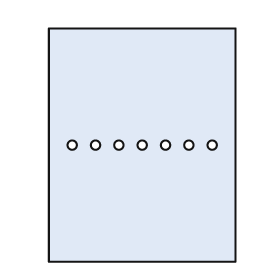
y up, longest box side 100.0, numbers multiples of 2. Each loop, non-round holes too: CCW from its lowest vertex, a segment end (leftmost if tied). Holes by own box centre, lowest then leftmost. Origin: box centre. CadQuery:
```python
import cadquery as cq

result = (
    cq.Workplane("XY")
    .moveTo(-40.0, -50.0)
    .lineTo(40.0, -50.0)
    .lineTo(40.0, 50.0)
    .lineTo(-40.0, 50.0)
    .close()
    .moveTo(-30.0, 0.0)
    .circle(2.0)
    .moveTo(-20.0, 0.0)
    .circle(2.0)
    .moveTo(-10.0, 0.0)
    .circle(2.0)
    .moveTo(0.0, 0.0)
    .circle(2.0)
    .moveTo(10.0, 0.0)
    .circle(2.0)
    .moveTo(20.0, 0.0)
    .circle(2.0)
    .moveTo(30.0, 0.0)
    .circle(2.0)
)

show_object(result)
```